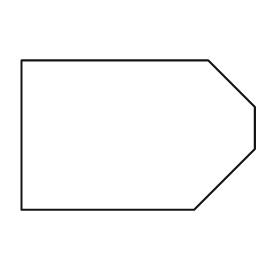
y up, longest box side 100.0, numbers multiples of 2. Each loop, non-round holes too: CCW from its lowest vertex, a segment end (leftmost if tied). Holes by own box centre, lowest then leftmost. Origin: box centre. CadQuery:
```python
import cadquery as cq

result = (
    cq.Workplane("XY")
    .moveTo(-50.0, -32.0)
    .lineTo(24.0, -32.0)
    .lineTo(50.0, -6.0)
    .lineTo(50.0, 12.0)
    .lineTo(30.0, 32.0)
    .lineTo(-50.0, 32.0)
    .close()
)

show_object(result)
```